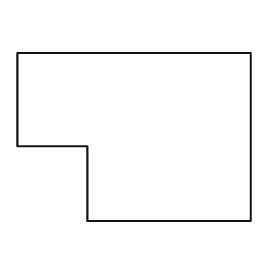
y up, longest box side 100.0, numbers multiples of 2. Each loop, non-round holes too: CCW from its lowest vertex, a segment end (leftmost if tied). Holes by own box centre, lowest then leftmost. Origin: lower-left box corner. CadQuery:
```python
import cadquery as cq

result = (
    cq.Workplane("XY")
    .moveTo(30.0, 0.0)
    .lineTo(100.0, 0.0)
    .lineTo(100.0, 72.0)
    .lineTo(0.0, 72.0)
    .lineTo(0.0, 32.0)
    .lineTo(30.0, 32.0)
    .close()
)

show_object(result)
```